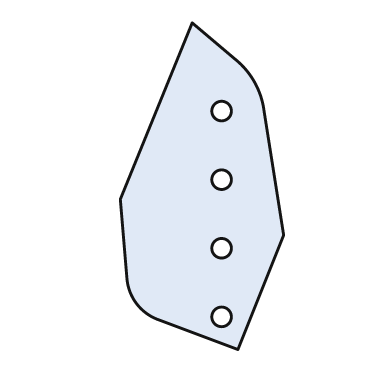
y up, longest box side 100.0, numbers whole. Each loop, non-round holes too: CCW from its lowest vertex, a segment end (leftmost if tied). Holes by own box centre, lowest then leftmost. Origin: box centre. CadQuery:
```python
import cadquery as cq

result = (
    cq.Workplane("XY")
    .moveTo(11.0, -50.0)
    .lineTo(25.0, -15.0)
    .lineTo(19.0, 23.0)
    .threePointArc((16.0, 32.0), (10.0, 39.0))
    .lineTo(-3.0, 50.0)
    .lineTo(-25.0, -4.0)
    .lineTo(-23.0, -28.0)
    .threePointArc((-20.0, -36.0), (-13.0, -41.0))
    .close()
    .moveTo(6.0, -40.0)
    .circle(3.0)
    .moveTo(6.0, -19.0)
    .circle(3.0)
    .moveTo(6.0, 2.0)
    .circle(3.0)
    .moveTo(6.0, 23.0)
    .circle(3.0)
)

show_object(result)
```